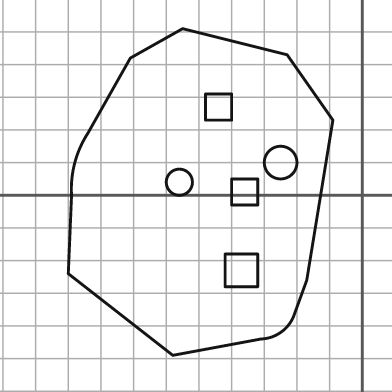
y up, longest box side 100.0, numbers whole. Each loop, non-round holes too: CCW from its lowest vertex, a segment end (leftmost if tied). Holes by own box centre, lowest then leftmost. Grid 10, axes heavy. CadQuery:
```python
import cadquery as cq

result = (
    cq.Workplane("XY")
    .moveTo(-58.0, -49.0)
    .lineTo(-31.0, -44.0)
    .threePointArc((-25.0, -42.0), (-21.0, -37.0))
    .lineTo(-17.0, -26.0)
    .lineTo(-9.0, 23.0)
    .lineTo(-23.0, 43.0)
    .lineTo(-55.0, 51.0)
    .lineTo(-71.0, 42.0)
    .lineTo(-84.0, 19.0)
    .threePointArc((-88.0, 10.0), (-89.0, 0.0))
    .lineTo(-90.0, -24.0)
    .close()
    .moveTo(-42.0, -28.0)
    .lineTo(-32.0, -28.0)
    .lineTo(-32.0, -18.0)
    .lineTo(-42.0, -18.0)
    .close()
    .moveTo(-40.0, -3.0)
    .lineTo(-32.0, -3.0)
    .lineTo(-32.0, 5.0)
    .lineTo(-40.0, 5.0)
    .close()
    .moveTo(-56.0, 4.0)
    .circle(4.0)
    .moveTo(-25.0, 10.0)
    .circle(5.0)
    .moveTo(-48.0, 23.0)
    .lineTo(-40.0, 23.0)
    .lineTo(-40.0, 31.0)
    .lineTo(-48.0, 31.0)
    .close()
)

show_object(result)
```